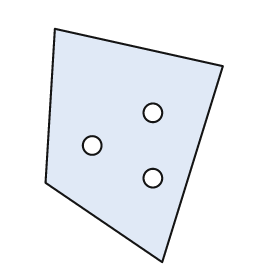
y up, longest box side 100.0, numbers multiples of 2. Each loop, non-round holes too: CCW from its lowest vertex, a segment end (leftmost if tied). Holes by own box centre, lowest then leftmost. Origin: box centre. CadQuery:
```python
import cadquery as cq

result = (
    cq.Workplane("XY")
    .moveTo(12.0, -50.0)
    .lineTo(38.0, 34.0)
    .lineTo(-34.0, 50.0)
    .lineTo(-38.0, -16.0)
    .close()
    .moveTo(8.0, -14.0)
    .circle(4.0)
    .moveTo(-18.0, 0.0)
    .circle(4.0)
    .moveTo(8.0, 14.0)
    .circle(4.0)
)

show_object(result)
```